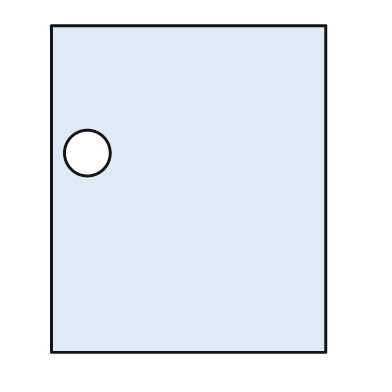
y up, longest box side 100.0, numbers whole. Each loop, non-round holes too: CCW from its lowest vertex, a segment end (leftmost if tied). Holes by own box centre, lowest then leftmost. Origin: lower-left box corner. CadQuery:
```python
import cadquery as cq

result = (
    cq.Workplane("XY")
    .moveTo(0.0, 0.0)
    .lineTo(84.0, 0.0)
    .lineTo(84.0, 100.0)
    .lineTo(0.0, 100.0)
    .close()
    .moveTo(11.0, 61.0)
    .circle(7.0)
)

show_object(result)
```